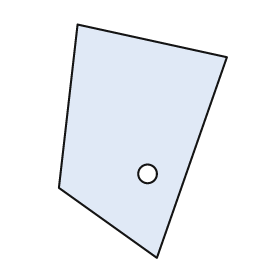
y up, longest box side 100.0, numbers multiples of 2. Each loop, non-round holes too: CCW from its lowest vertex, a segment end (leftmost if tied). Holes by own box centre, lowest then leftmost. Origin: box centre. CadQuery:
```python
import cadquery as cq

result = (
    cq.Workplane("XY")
    .moveTo(6.0, -50.0)
    .lineTo(36.0, 36.0)
    .lineTo(-28.0, 50.0)
    .lineTo(-36.0, -20.0)
    .close()
    .moveTo(2.0, -14.0)
    .circle(4.0)
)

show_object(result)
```